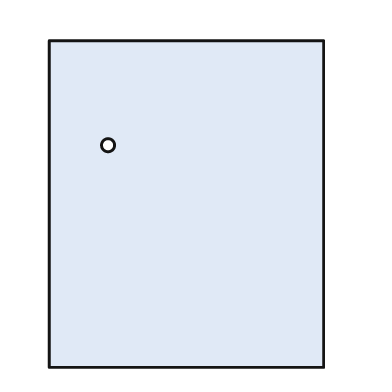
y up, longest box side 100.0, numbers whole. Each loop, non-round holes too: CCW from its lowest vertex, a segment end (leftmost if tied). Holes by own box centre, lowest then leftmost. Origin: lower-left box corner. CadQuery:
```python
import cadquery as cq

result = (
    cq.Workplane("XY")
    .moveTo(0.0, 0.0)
    .lineTo(84.0, 0.0)
    .lineTo(84.0, 100.0)
    .lineTo(0.0, 100.0)
    .close()
    .moveTo(18.0, 68.0)
    .circle(2.0)
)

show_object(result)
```